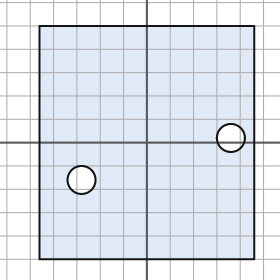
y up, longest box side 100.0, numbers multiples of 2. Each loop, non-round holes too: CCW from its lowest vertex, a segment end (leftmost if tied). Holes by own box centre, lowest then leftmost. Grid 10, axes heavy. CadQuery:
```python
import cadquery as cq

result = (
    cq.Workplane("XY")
    .moveTo(-46.0, -50.0)
    .lineTo(46.0, -50.0)
    .lineTo(46.0, 50.0)
    .lineTo(-46.0, 50.0)
    .close()
    .moveTo(-28.0, -16.0)
    .circle(6.0)
    .moveTo(36.0, 2.0)
    .circle(6.0)
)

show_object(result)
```